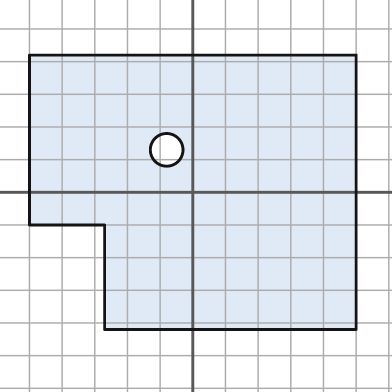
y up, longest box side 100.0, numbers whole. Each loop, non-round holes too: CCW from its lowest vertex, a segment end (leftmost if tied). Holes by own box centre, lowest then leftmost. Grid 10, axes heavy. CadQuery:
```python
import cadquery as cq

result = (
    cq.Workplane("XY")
    .moveTo(-27.0, -42.0)
    .lineTo(50.0, -42.0)
    .lineTo(50.0, 42.0)
    .lineTo(-50.0, 42.0)
    .lineTo(-50.0, -10.0)
    .lineTo(-27.0, -10.0)
    .close()
    .moveTo(-8.0, 13.0)
    .circle(5.0)
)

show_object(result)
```